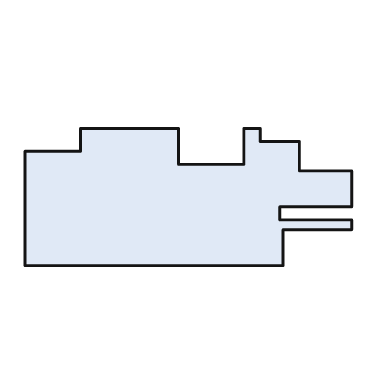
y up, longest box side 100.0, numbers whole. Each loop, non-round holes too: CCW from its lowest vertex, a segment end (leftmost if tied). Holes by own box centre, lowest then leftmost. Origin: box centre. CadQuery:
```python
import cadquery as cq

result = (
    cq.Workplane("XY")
    .moveTo(-50.0, -21.0)
    .lineTo(29.0, -21.0)
    .lineTo(29.0, -10.0)
    .lineTo(50.0, -10.0)
    .lineTo(50.0, -7.0)
    .lineTo(28.0, -7.0)
    .lineTo(28.0, -3.0)
    .lineTo(50.0, -3.0)
    .lineTo(50.0, 8.0)
    .lineTo(34.0, 8.0)
    .lineTo(34.0, 17.0)
    .lineTo(22.0, 17.0)
    .lineTo(22.0, 21.0)
    .lineTo(17.0, 21.0)
    .lineTo(17.0, 10.0)
    .lineTo(-3.0, 10.0)
    .lineTo(-3.0, 21.0)
    .lineTo(-33.0, 21.0)
    .lineTo(-33.0, 14.0)
    .lineTo(-50.0, 14.0)
    .close()
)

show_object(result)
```